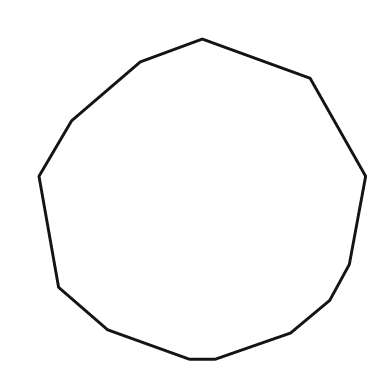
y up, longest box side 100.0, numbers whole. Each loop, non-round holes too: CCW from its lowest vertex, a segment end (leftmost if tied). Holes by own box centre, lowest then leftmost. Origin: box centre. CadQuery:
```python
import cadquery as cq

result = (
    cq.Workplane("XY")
    .moveTo(-4.0, -49.0)
    .lineTo(4.0, -49.0)
    .lineTo(27.0, -41.0)
    .lineTo(39.0, -31.0)
    .lineTo(45.0, -20.0)
    .lineTo(50.0, 7.0)
    .lineTo(33.0, 37.0)
    .lineTo(0.0, 49.0)
    .lineTo(-19.0, 42.0)
    .lineTo(-40.0, 24.0)
    .lineTo(-50.0, 7.0)
    .lineTo(-44.0, -27.0)
    .lineTo(-29.0, -40.0)
    .close()
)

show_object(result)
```